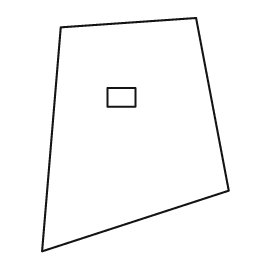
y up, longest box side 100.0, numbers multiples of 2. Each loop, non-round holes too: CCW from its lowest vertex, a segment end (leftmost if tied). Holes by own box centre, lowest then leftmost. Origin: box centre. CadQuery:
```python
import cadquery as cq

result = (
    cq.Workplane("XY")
    .moveTo(-40.0, -50.0)
    .lineTo(40.0, -24.0)
    .lineTo(26.0, 50.0)
    .lineTo(-32.0, 46.0)
    .close()
    .moveTo(-12.0, 12.0)
    .lineTo(0.0, 12.0)
    .lineTo(0.0, 20.0)
    .lineTo(-12.0, 20.0)
    .close()
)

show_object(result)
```